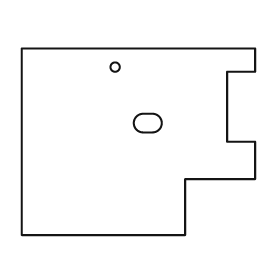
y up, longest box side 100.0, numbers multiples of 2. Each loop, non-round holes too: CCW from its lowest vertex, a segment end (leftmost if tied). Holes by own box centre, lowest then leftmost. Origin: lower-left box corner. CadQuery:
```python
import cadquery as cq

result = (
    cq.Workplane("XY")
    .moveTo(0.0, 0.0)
    .lineTo(70.0, 0.0)
    .lineTo(70.0, 24.0)
    .lineTo(100.0, 24.0)
    .lineTo(100.0, 40.0)
    .lineTo(88.0, 40.0)
    .lineTo(88.0, 70.0)
    .lineTo(100.0, 70.0)
    .lineTo(100.0, 80.0)
    .lineTo(0.0, 80.0)
    .close()
    .moveTo(52.0, 44.0)
    .lineTo(56.0, 44.0)
    .threePointArc((60.0, 48.0), (56.0, 52.0))
    .lineTo(52.0, 52.0)
    .threePointArc((48.0, 48.0), (52.0, 44.0))
    .close()
    .moveTo(40.0, 72.0)
    .circle(2.0)
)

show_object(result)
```